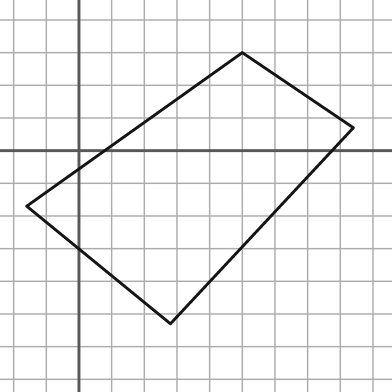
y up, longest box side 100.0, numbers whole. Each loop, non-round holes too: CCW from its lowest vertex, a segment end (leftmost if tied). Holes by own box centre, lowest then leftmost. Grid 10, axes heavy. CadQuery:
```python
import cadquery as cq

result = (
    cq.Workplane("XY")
    .moveTo(28.0, -53.0)
    .lineTo(84.0, 7.0)
    .lineTo(50.0, 30.0)
    .lineTo(-16.0, -17.0)
    .close()
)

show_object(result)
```